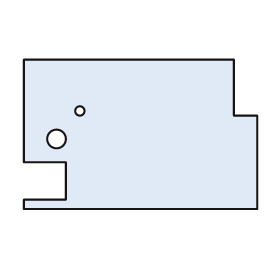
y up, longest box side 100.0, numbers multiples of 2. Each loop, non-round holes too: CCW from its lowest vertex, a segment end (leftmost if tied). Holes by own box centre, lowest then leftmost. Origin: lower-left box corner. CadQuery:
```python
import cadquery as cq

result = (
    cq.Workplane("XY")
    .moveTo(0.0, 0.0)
    .lineTo(100.0, 0.0)
    .lineTo(100.0, 40.0)
    .lineTo(90.0, 40.0)
    .lineTo(90.0, 64.0)
    .lineTo(0.0, 64.0)
    .lineTo(0.0, 20.0)
    .lineTo(18.0, 20.0)
    .lineTo(18.0, 4.0)
    .lineTo(0.0, 4.0)
    .close()
    .moveTo(14.0, 30.0)
    .circle(4.0)
    .moveTo(24.0, 42.0)
    .circle(2.0)
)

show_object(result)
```